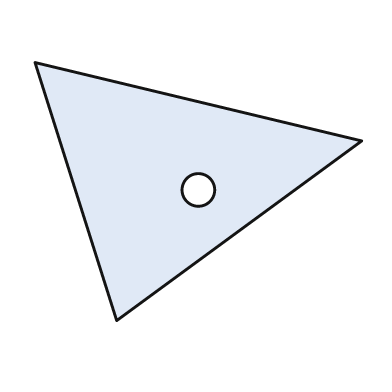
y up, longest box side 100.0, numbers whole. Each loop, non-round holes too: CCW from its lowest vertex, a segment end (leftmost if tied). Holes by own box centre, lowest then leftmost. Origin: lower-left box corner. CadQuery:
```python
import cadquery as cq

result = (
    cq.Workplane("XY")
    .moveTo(25.0, 0.0)
    .lineTo(100.0, 55.0)
    .lineTo(0.0, 79.0)
    .close()
    .moveTo(50.0, 40.0)
    .circle(5.0)
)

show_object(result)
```